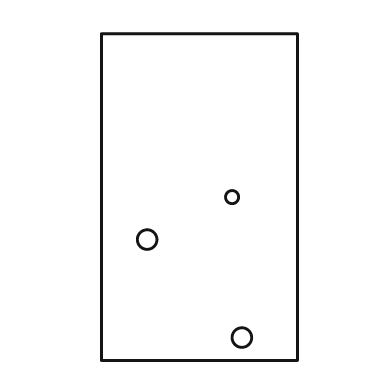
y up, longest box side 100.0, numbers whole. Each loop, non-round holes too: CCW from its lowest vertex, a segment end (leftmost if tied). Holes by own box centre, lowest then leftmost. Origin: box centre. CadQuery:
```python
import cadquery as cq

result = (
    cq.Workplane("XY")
    .moveTo(-30.0, -50.0)
    .lineTo(30.0, -50.0)
    .lineTo(30.0, 50.0)
    .lineTo(-30.0, 50.0)
    .close()
    .moveTo(13.0, -43.0)
    .circle(3.0)
    .moveTo(-16.0, -13.0)
    .circle(3.0)
    .moveTo(10.0, 0.0)
    .circle(2.0)
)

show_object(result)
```